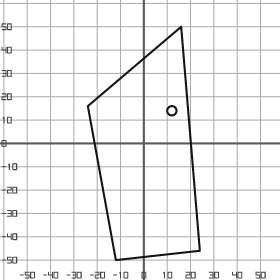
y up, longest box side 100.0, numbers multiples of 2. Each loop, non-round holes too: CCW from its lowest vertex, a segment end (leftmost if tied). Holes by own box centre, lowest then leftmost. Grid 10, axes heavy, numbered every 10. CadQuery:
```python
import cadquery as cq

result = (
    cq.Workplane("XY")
    .moveTo(-12.0, -50.0)
    .lineTo(24.0, -46.0)
    .lineTo(16.0, 50.0)
    .lineTo(-24.0, 16.0)
    .close()
    .moveTo(12.0, 14.0)
    .circle(2.0)
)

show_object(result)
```